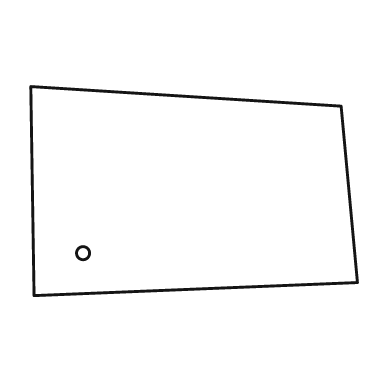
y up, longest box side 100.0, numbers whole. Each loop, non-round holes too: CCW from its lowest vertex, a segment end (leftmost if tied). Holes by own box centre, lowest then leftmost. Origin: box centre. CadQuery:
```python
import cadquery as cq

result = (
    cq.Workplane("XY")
    .moveTo(-49.0, -32.0)
    .lineTo(50.0, -28.0)
    .lineTo(45.0, 26.0)
    .lineTo(-50.0, 32.0)
    .close()
    .moveTo(-34.0, -19.0)
    .circle(2.0)
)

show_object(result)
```